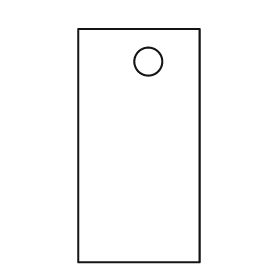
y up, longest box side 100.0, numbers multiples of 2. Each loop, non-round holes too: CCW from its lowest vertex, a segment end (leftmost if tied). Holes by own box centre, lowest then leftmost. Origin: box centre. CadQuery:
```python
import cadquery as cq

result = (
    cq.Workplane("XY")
    .moveTo(-26.0, -50.0)
    .lineTo(26.0, -50.0)
    .lineTo(26.0, 50.0)
    .lineTo(-26.0, 50.0)
    .close()
    .moveTo(4.0, 36.0)
    .circle(6.0)
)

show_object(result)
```